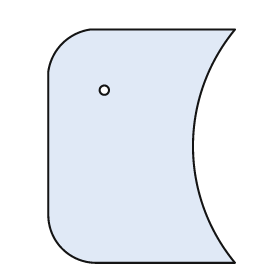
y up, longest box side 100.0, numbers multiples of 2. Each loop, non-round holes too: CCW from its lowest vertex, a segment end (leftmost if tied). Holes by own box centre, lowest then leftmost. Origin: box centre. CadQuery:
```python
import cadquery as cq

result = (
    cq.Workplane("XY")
    .moveTo(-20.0, -50.0)
    .lineTo(40.0, -50.0)
    .threePointArc((22.0, 0.0), (40.0, 50.0))
    .lineTo(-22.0, 50.0)
    .threePointArc((-34.0, 44.0), (-40.0, 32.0))
    .lineTo(-40.0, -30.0)
    .threePointArc((-34.0, -44.0), (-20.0, -50.0))
    .close()
    .moveTo(-16.0, 24.0)
    .circle(2.0)
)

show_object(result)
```